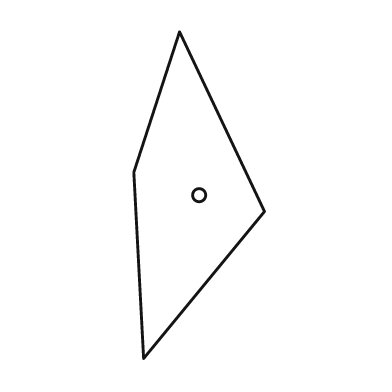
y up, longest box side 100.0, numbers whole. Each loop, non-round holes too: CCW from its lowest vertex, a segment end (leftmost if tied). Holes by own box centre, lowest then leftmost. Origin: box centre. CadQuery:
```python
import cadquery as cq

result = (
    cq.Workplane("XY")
    .moveTo(-17.0, -50.0)
    .lineTo(20.0, -5.0)
    .lineTo(-6.0, 50.0)
    .lineTo(-20.0, 7.0)
    .close()
    .moveTo(0.0, 0.0)
    .circle(2.0)
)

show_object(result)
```